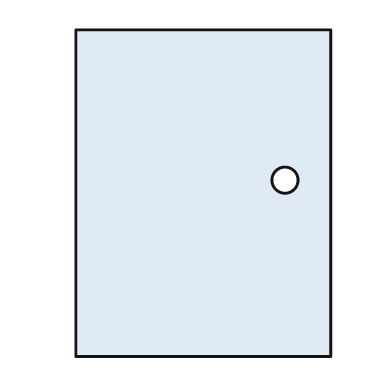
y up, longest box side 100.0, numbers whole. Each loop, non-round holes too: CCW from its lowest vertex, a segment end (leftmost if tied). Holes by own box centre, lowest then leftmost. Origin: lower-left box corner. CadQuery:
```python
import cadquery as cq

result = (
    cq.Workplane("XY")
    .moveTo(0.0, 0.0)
    .lineTo(78.0, 0.0)
    .lineTo(78.0, 100.0)
    .lineTo(0.0, 100.0)
    .close()
    .moveTo(64.0, 54.0)
    .circle(4.0)
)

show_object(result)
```